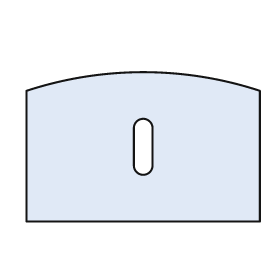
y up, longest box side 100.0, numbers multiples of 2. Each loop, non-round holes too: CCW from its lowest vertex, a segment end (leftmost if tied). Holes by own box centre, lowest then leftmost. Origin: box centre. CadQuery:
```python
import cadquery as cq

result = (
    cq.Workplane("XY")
    .moveTo(-50.0, -32.0)
    .lineTo(50.0, -32.0)
    .lineTo(50.0, 24.0)
    .threePointArc((0.0, 32.0), (-50.0, 24.0))
    .close()
    .moveTo(-4.0, -8.0)
    .threePointArc((0.0, -12.0), (4.0, -8.0))
    .lineTo(4.0, 8.0)
    .threePointArc((0.0, 12.0), (-4.0, 8.0))
    .close()
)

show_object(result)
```